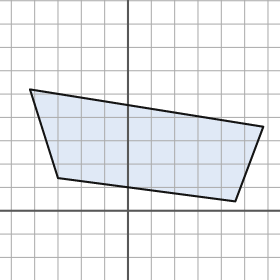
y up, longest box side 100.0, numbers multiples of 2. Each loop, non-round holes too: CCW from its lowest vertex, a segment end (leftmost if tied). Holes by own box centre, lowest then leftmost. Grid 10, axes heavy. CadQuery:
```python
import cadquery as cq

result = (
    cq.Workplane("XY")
    .moveTo(46.0, 4.0)
    .lineTo(58.0, 36.0)
    .lineTo(-42.0, 52.0)
    .lineTo(-30.0, 14.0)
    .close()
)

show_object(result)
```